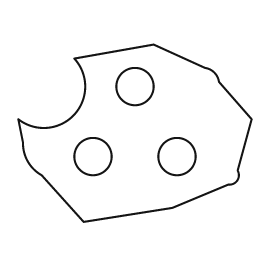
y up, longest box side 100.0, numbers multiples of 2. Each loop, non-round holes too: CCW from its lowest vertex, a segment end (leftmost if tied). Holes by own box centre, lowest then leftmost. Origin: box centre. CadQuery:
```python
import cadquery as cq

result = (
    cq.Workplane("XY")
    .moveTo(-22.0, -38.0)
    .lineTo(16.0, -32.0)
    .lineTo(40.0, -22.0)
    .threePointArc((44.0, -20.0), (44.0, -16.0))
    .lineTo(50.0, 6.0)
    .lineTo(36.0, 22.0)
    .threePointArc((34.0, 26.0), (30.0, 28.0))
    .lineTo(8.0, 38.0)
    .lineTo(-26.0, 32.0)
    .threePointArc((-26.0, 8.0), (-50.0, 6.0))
    .lineTo(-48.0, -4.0)
    .threePointArc((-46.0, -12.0), (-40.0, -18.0))
    .close()
    .moveTo(-18.0, -10.0)
    .circle(8.0)
    .moveTo(18.0, -10.0)
    .circle(8.0)
    .moveTo(0.0, 20.0)
    .circle(8.0)
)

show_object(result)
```